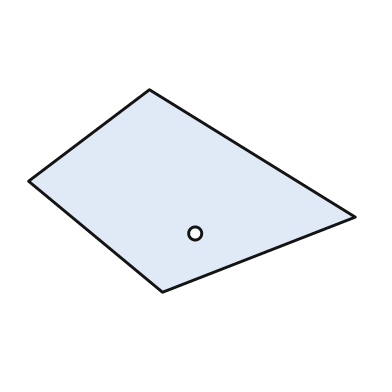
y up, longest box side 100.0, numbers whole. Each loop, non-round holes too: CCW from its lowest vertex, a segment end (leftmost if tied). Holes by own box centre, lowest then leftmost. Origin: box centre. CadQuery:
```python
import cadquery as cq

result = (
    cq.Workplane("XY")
    .moveTo(-9.0, -31.0)
    .lineTo(50.0, -8.0)
    .lineTo(-13.0, 31.0)
    .lineTo(-50.0, 3.0)
    .close()
    .moveTo(1.0, -13.0)
    .circle(2.0)
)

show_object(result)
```